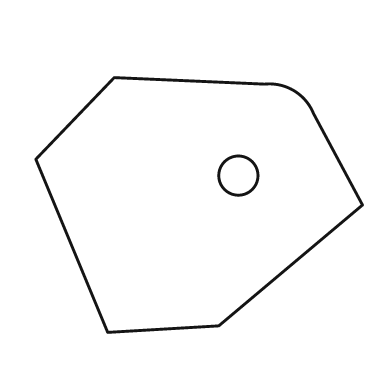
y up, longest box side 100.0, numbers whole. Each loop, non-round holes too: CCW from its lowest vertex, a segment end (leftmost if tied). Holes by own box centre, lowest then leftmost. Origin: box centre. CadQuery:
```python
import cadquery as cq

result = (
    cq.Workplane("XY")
    .moveTo(-28.0, -39.0)
    .lineTo(6.0, -37.0)
    .lineTo(50.0, 0.0)
    .lineTo(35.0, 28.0)
    .threePointArc((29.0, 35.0), (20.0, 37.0))
    .lineTo(-26.0, 39.0)
    .lineTo(-50.0, 14.0)
    .close()
    .moveTo(12.0, 9.0)
    .circle(6.0)
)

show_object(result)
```